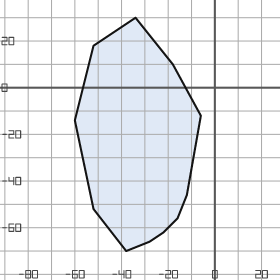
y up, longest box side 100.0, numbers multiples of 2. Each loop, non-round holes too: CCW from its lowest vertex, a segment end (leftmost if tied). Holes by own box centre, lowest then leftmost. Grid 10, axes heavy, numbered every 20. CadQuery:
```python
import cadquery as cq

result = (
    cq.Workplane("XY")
    .moveTo(-38.0, -70.0)
    .lineTo(-28.0, -66.0)
    .lineTo(-22.0, -62.0)
    .lineTo(-16.0, -56.0)
    .lineTo(-12.0, -46.0)
    .lineTo(-6.0, -12.0)
    .lineTo(-18.0, 10.0)
    .lineTo(-34.0, 30.0)
    .lineTo(-52.0, 18.0)
    .lineTo(-60.0, -14.0)
    .lineTo(-52.0, -52.0)
    .close()
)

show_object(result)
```